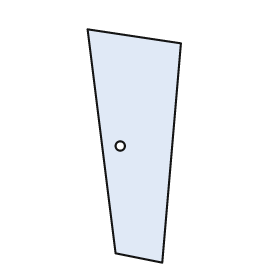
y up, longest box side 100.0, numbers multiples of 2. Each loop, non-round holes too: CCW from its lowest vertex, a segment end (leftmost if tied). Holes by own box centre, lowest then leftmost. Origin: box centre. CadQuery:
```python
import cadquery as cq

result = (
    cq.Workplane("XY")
    .moveTo(12.0, -50.0)
    .lineTo(20.0, 44.0)
    .lineTo(-20.0, 50.0)
    .lineTo(-8.0, -46.0)
    .close()
    .moveTo(-6.0, 0.0)
    .circle(2.0)
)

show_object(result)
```